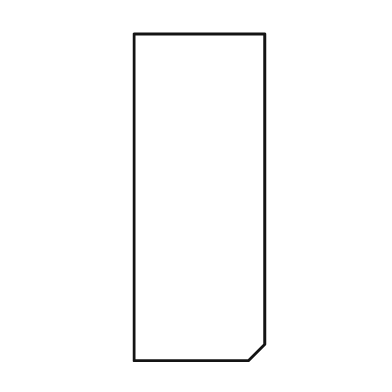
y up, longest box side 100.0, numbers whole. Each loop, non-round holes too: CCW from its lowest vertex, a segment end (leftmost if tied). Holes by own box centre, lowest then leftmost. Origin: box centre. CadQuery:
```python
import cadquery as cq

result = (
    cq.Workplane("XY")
    .moveTo(-20.0, -50.0)
    .lineTo(15.0, -50.0)
    .lineTo(20.0, -45.0)
    .lineTo(20.0, 50.0)
    .lineTo(-20.0, 50.0)
    .close()
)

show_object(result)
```